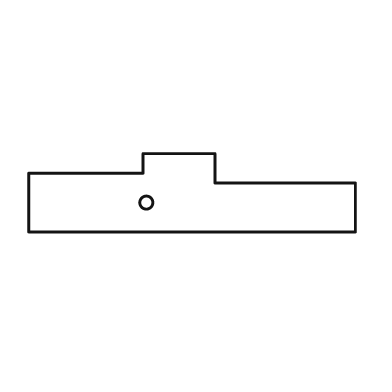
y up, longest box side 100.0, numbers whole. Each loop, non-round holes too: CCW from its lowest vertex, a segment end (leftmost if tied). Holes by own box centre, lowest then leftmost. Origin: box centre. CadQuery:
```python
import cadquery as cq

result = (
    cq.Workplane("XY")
    .moveTo(-50.0, -12.0)
    .lineTo(50.0, -12.0)
    .lineTo(50.0, 3.0)
    .lineTo(7.0, 3.0)
    .lineTo(7.0, 12.0)
    .lineTo(-15.0, 12.0)
    .lineTo(-15.0, 6.0)
    .lineTo(-50.0, 6.0)
    .close()
    .moveTo(-14.0, -3.0)
    .circle(2.0)
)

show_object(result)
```